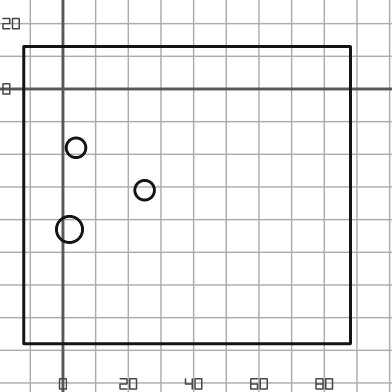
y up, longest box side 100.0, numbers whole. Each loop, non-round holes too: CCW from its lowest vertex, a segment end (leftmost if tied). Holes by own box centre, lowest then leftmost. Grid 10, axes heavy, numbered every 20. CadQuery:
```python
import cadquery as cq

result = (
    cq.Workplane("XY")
    .moveTo(-12.0, -78.0)
    .lineTo(88.0, -78.0)
    .lineTo(88.0, 13.0)
    .lineTo(-12.0, 13.0)
    .close()
    .moveTo(2.0, -43.0)
    .circle(4.0)
    .moveTo(25.0, -31.0)
    .circle(3.0)
    .moveTo(4.0, -18.0)
    .circle(3.0)
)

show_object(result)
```